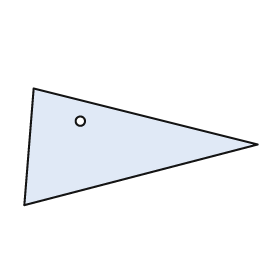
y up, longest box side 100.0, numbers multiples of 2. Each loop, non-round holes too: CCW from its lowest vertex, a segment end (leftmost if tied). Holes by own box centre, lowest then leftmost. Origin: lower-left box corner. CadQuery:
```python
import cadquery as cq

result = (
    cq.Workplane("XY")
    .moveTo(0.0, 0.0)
    .lineTo(100.0, 26.0)
    .lineTo(4.0, 50.0)
    .close()
    .moveTo(24.0, 36.0)
    .circle(2.0)
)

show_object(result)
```